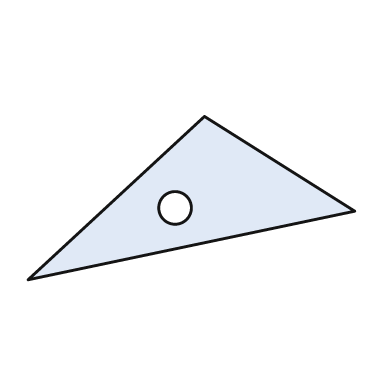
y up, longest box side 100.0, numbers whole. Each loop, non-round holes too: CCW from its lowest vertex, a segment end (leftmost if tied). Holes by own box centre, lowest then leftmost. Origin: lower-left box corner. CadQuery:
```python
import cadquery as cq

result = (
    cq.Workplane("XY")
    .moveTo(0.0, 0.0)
    .lineTo(100.0, 21.0)
    .lineTo(54.0, 50.0)
    .close()
    .moveTo(45.0, 22.0)
    .circle(5.0)
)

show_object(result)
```